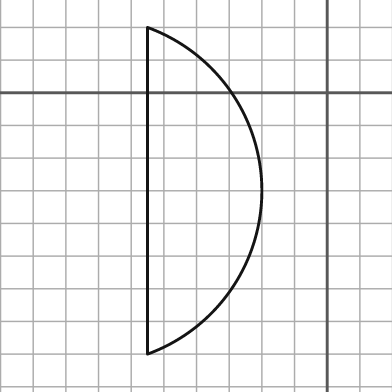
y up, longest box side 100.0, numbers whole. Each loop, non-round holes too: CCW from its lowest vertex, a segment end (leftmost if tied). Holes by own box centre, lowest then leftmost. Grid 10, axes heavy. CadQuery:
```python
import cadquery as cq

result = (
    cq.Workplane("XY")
    .moveTo(-55.0, -80.0)
    .threePointArc((-20.0, -30.0), (-55.0, 20.0))
    .close()
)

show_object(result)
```